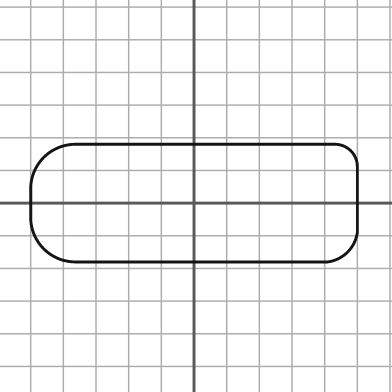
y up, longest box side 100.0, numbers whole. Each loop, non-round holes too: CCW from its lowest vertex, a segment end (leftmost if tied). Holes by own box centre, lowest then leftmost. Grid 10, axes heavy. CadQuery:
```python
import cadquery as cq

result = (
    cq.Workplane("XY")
    .moveTo(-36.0, -18.0)
    .lineTo(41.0, -18.0)
    .threePointArc((47.0, -15.0), (50.0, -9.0))
    .lineTo(50.0, 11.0)
    .threePointArc((48.0, 16.0), (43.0, 18.0))
    .lineTo(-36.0, 18.0)
    .threePointArc((-46.0, 14.0), (-50.0, 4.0))
    .lineTo(-50.0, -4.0)
    .threePointArc((-46.0, -14.0), (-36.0, -18.0))
    .close()
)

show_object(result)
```